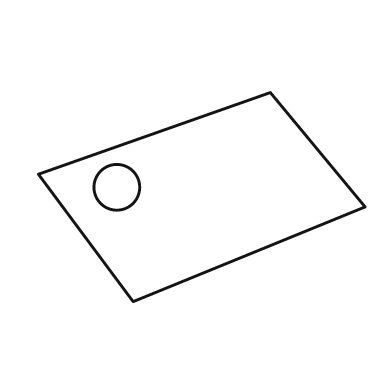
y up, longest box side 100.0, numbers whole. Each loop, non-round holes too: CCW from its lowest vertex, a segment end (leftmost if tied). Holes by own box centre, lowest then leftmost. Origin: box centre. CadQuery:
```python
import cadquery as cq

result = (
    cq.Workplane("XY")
    .moveTo(-21.0, -32.0)
    .lineTo(50.0, -3.0)
    .lineTo(21.0, 32.0)
    .lineTo(-50.0, 7.0)
    .close()
    .moveTo(-26.0, 3.0)
    .circle(7.0)
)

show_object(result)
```